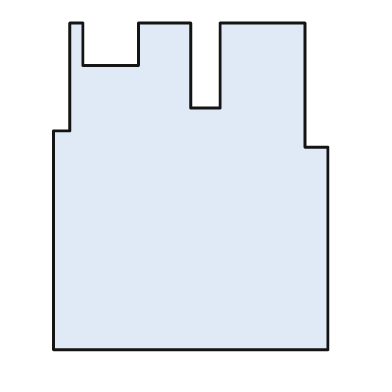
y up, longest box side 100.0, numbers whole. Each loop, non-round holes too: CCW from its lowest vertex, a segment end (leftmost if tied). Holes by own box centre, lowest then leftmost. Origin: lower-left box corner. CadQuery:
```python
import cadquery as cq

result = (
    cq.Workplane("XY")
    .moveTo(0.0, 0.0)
    .lineTo(84.0, 0.0)
    .lineTo(84.0, 62.0)
    .lineTo(77.0, 62.0)
    .lineTo(77.0, 100.0)
    .lineTo(51.0, 100.0)
    .lineTo(51.0, 74.0)
    .lineTo(42.0, 74.0)
    .lineTo(42.0, 100.0)
    .lineTo(26.0, 100.0)
    .lineTo(26.0, 87.0)
    .lineTo(9.0, 87.0)
    .lineTo(9.0, 100.0)
    .lineTo(5.0, 100.0)
    .lineTo(5.0, 67.0)
    .lineTo(0.0, 67.0)
    .close()
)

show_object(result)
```